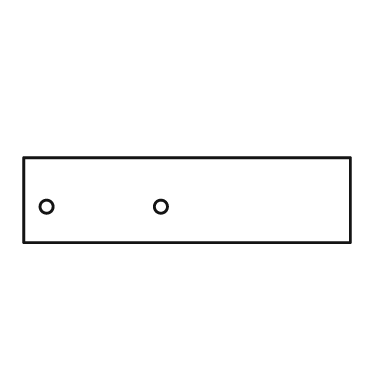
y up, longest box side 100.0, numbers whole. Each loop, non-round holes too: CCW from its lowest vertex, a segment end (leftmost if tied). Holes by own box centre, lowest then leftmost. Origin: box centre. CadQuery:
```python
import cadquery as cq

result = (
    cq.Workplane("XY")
    .moveTo(-50.0, -13.0)
    .lineTo(50.0, -13.0)
    .lineTo(50.0, 13.0)
    .lineTo(-50.0, 13.0)
    .close()
    .moveTo(-43.0, -2.0)
    .circle(2.0)
    .moveTo(-8.0, -2.0)
    .circle(2.0)
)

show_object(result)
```